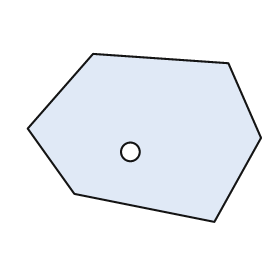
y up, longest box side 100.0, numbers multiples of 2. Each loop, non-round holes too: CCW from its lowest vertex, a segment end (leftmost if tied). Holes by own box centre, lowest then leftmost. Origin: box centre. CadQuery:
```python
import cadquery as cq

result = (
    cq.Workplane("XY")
    .moveTo(30.0, -36.0)
    .lineTo(50.0, 0.0)
    .lineTo(36.0, 32.0)
    .lineTo(-22.0, 36.0)
    .lineTo(-50.0, 4.0)
    .lineTo(-30.0, -24.0)
    .close()
    .moveTo(-6.0, -6.0)
    .circle(4.0)
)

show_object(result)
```